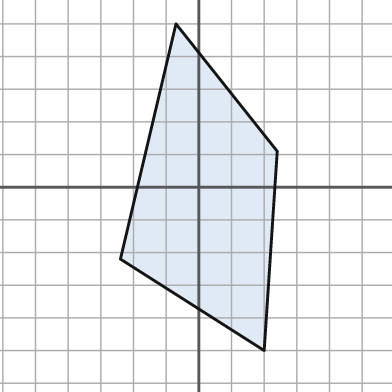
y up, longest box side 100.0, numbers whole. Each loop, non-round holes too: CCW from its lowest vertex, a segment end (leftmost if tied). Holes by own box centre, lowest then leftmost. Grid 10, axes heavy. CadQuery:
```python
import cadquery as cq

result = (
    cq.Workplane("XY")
    .moveTo(20.0, -50.0)
    .lineTo(24.0, 11.0)
    .lineTo(-7.0, 50.0)
    .lineTo(-24.0, -22.0)
    .close()
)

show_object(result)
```